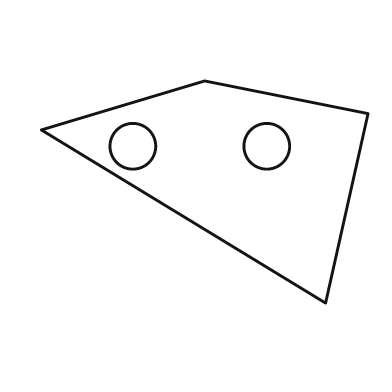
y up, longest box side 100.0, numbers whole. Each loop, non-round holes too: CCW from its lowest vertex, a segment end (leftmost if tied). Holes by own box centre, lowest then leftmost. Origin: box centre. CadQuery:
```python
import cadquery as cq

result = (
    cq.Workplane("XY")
    .moveTo(37.0, -34.0)
    .lineTo(50.0, 24.0)
    .lineTo(0.0, 34.0)
    .lineTo(-50.0, 19.0)
    .close()
    .moveTo(-22.0, 14.0)
    .circle(7.0)
    .moveTo(19.0, 14.0)
    .circle(7.0)
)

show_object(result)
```